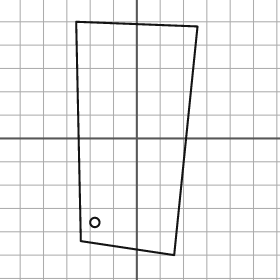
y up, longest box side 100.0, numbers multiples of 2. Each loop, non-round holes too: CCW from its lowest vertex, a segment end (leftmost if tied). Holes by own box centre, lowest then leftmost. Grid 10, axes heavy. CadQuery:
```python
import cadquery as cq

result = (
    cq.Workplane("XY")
    .moveTo(16.0, -50.0)
    .lineTo(26.0, 48.0)
    .lineTo(-26.0, 50.0)
    .lineTo(-24.0, -44.0)
    .close()
    .moveTo(-18.0, -36.0)
    .circle(2.0)
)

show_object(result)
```